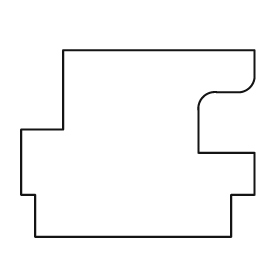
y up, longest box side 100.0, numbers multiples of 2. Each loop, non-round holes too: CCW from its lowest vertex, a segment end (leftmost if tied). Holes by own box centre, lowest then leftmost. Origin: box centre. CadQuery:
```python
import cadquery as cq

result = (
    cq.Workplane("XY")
    .moveTo(-44.0, -40.0)
    .lineTo(40.0, -40.0)
    .lineTo(40.0, -22.0)
    .lineTo(50.0, -22.0)
    .lineTo(50.0, -4.0)
    .lineTo(26.0, -4.0)
    .lineTo(26.0, 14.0)
    .threePointArc((28.0, 20.0), (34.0, 22.0))
    .lineTo(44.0, 22.0)
    .threePointArc((48.0, 24.0), (50.0, 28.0))
    .lineTo(50.0, 40.0)
    .lineTo(-32.0, 40.0)
    .lineTo(-32.0, 6.0)
    .lineTo(-50.0, 6.0)
    .lineTo(-50.0, -22.0)
    .lineTo(-44.0, -22.0)
    .close()
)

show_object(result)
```